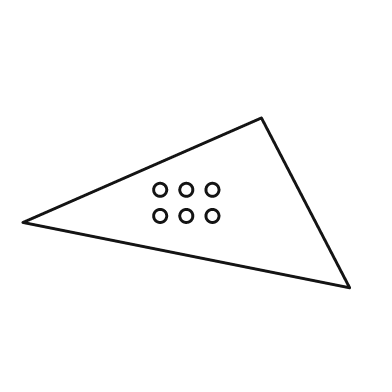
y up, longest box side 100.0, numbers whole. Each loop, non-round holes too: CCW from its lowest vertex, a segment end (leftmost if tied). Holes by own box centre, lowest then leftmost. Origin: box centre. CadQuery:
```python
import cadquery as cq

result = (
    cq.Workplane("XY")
    .moveTo(50.0, -26.0)
    .lineTo(23.0, 26.0)
    .lineTo(-50.0, -6.0)
    .close()
    .moveTo(-8.0, -4.0)
    .circle(2.0)
    .moveTo(0.0, -4.0)
    .circle(2.0)
    .moveTo(8.0, -4.0)
    .circle(2.0)
    .moveTo(-8.0, 4.0)
    .circle(2.0)
    .moveTo(0.0, 4.0)
    .circle(2.0)
    .moveTo(8.0, 4.0)
    .circle(2.0)
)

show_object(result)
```